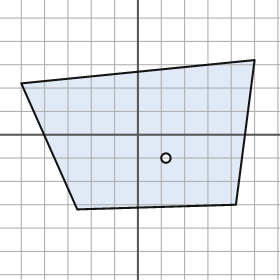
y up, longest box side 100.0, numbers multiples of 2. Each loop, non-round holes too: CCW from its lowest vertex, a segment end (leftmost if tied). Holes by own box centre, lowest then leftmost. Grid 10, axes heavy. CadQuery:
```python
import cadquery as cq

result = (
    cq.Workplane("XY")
    .moveTo(-26.0, -32.0)
    .lineTo(42.0, -30.0)
    .lineTo(50.0, 32.0)
    .lineTo(-50.0, 22.0)
    .close()
    .moveTo(12.0, -10.0)
    .circle(2.0)
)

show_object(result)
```